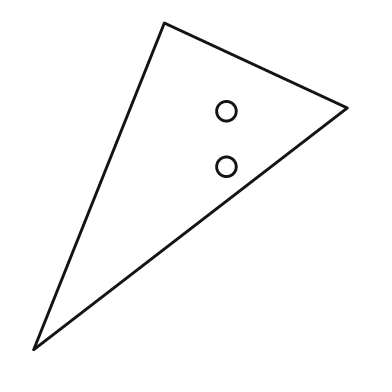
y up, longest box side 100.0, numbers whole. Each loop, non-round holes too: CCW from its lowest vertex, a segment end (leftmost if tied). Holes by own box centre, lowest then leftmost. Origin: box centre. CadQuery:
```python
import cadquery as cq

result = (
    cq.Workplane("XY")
    .moveTo(-48.0, -50.0)
    .lineTo(48.0, 24.0)
    .lineTo(-8.0, 50.0)
    .close()
    .moveTo(11.0, 6.0)
    .circle(3.0)
    .moveTo(11.0, 23.0)
    .circle(3.0)
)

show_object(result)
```